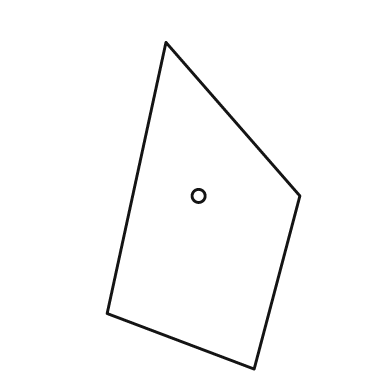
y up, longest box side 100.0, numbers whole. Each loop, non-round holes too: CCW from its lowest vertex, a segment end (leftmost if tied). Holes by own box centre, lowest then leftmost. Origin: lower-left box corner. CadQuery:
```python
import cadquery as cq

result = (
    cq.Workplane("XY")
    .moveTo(45.0, 0.0)
    .lineTo(59.0, 53.0)
    .lineTo(18.0, 100.0)
    .lineTo(0.0, 17.0)
    .close()
    .moveTo(28.0, 53.0)
    .circle(2.0)
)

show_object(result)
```